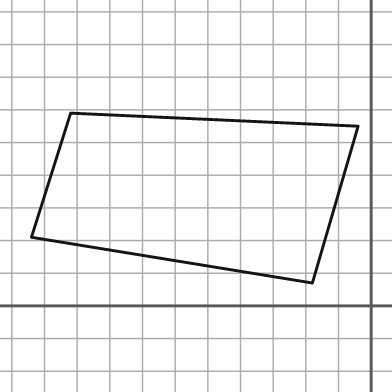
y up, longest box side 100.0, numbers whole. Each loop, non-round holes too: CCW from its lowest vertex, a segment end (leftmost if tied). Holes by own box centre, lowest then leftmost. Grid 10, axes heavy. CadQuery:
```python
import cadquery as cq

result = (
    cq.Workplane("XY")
    .moveTo(-18.0, 7.0)
    .lineTo(-4.0, 55.0)
    .lineTo(-92.0, 59.0)
    .lineTo(-104.0, 21.0)
    .close()
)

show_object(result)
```